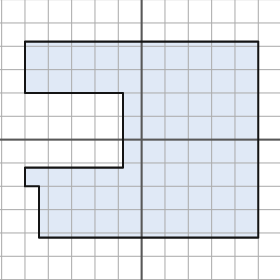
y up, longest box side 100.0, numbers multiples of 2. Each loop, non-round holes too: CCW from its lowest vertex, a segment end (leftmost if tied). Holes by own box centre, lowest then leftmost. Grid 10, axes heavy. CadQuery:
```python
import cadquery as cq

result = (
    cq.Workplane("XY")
    .moveTo(-44.0, -42.0)
    .lineTo(50.0, -42.0)
    .lineTo(50.0, 42.0)
    .lineTo(-50.0, 42.0)
    .lineTo(-50.0, 20.0)
    .lineTo(-8.0, 20.0)
    .lineTo(-8.0, -12.0)
    .lineTo(-50.0, -12.0)
    .lineTo(-50.0, -20.0)
    .lineTo(-44.0, -20.0)
    .close()
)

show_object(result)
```